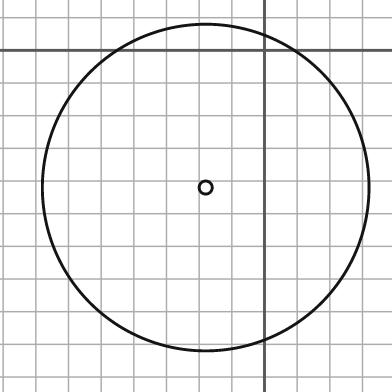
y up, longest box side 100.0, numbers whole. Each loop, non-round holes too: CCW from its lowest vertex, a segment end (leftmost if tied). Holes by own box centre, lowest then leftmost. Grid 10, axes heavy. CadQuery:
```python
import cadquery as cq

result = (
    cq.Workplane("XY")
    .moveTo(-18.0, -42.0)
    .circle(50.0)
    .moveTo(-18.0, -42.0)
    .circle(2.0)
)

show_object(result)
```